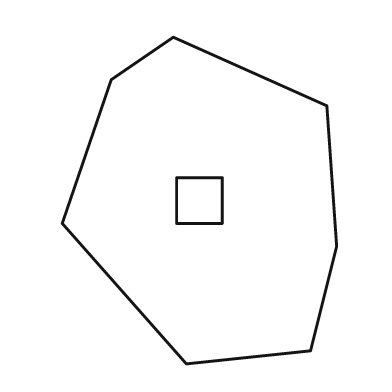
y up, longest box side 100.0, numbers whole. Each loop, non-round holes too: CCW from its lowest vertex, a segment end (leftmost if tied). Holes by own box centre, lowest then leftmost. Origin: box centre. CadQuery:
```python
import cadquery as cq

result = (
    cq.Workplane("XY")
    .moveTo(-4.0, -50.0)
    .lineTo(34.0, -46.0)
    .lineTo(42.0, -14.0)
    .lineTo(39.0, 29.0)
    .lineTo(-8.0, 50.0)
    .lineTo(-27.0, 37.0)
    .lineTo(-42.0, -7.0)
    .close()
    .moveTo(-7.0, -7.0)
    .lineTo(7.0, -7.0)
    .lineTo(7.0, 7.0)
    .lineTo(-7.0, 7.0)
    .close()
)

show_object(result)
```